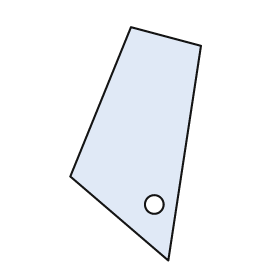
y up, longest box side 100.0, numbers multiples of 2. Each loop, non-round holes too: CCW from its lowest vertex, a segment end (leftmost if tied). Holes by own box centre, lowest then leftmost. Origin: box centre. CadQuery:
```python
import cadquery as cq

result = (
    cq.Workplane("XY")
    .moveTo(14.0, -50.0)
    .lineTo(28.0, 42.0)
    .lineTo(-2.0, 50.0)
    .lineTo(-28.0, -14.0)
    .close()
    .moveTo(8.0, -26.0)
    .circle(4.0)
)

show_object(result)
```